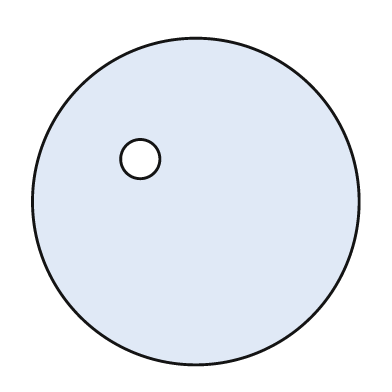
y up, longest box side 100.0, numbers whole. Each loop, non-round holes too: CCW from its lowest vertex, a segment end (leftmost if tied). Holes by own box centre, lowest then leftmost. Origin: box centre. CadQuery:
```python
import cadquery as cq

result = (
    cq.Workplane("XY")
    .moveTo(0.0, 0.0)
    .circle(50.0)
    .moveTo(-17.0, 13.0)
    .circle(6.0)
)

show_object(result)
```